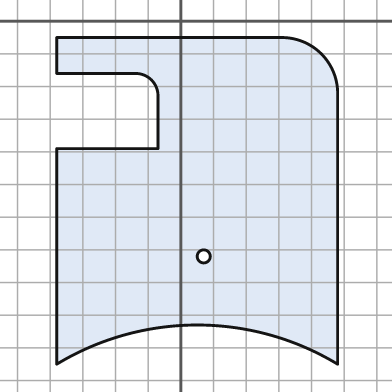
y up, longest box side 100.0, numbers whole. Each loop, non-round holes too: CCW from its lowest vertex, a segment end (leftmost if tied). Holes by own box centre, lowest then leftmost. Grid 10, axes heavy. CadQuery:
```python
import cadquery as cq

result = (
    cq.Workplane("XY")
    .moveTo(-38.0, -105.0)
    .threePointArc((5.0, -93.0), (48.0, -105.0))
    .lineTo(48.0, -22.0)
    .threePointArc((43.0, -10.0), (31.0, -5.0))
    .lineTo(-38.0, -5.0)
    .lineTo(-38.0, -16.0)
    .lineTo(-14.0, -16.0)
    .threePointArc((-9.0, -18.0), (-7.0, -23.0))
    .lineTo(-7.0, -39.0)
    .lineTo(-38.0, -39.0)
    .close()
    .moveTo(7.0, -72.0)
    .circle(2.0)
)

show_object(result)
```